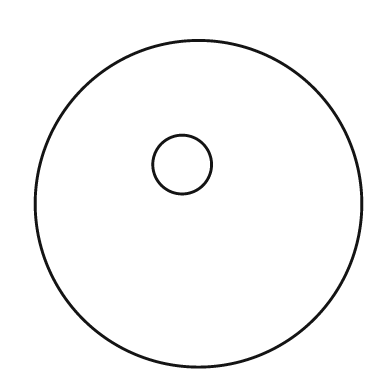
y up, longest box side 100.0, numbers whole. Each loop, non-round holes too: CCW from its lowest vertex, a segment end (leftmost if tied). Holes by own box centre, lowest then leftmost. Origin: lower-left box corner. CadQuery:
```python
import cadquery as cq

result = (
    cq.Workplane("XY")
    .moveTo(50.0, 50.0)
    .circle(50.0)
    .moveTo(45.0, 62.0)
    .circle(9.0)
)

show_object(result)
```